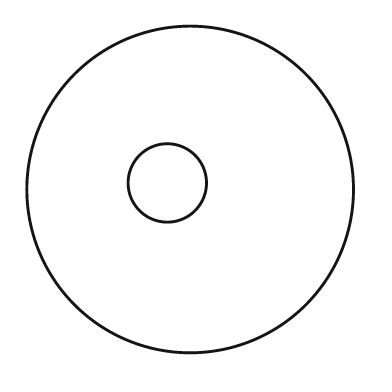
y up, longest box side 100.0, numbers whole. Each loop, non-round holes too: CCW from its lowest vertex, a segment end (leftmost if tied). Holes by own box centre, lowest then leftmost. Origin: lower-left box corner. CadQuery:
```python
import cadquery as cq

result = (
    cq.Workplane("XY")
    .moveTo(50.0, 50.0)
    .circle(50.0)
    .moveTo(43.0, 52.0)
    .circle(12.0)
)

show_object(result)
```